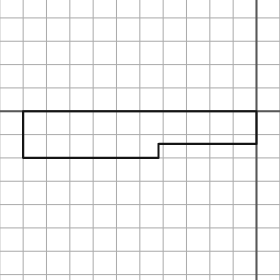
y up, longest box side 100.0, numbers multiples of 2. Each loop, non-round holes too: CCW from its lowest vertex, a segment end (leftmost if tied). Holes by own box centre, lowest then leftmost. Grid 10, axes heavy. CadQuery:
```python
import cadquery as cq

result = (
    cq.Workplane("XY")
    .moveTo(-100.0, -20.0)
    .lineTo(-42.0, -20.0)
    .lineTo(-42.0, -14.0)
    .lineTo(0.0, -14.0)
    .lineTo(0.0, 0.0)
    .lineTo(-100.0, 0.0)
    .close()
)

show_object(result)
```